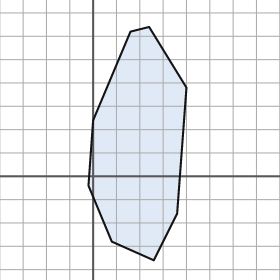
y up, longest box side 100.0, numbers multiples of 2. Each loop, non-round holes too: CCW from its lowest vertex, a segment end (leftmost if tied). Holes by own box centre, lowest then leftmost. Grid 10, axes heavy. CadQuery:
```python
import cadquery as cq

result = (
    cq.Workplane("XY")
    .moveTo(26.0, -36.0)
    .lineTo(36.0, -16.0)
    .lineTo(40.0, 38.0)
    .lineTo(24.0, 64.0)
    .lineTo(16.0, 62.0)
    .lineTo(0.0, 24.0)
    .lineTo(-2.0, -4.0)
    .lineTo(8.0, -28.0)
    .close()
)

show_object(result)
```